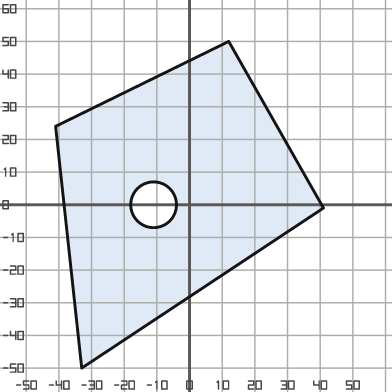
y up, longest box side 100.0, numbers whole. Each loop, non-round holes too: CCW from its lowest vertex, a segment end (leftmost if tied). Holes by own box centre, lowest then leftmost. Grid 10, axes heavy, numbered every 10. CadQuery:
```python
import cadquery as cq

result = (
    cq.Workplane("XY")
    .moveTo(-33.0, -50.0)
    .lineTo(41.0, -1.0)
    .lineTo(12.0, 50.0)
    .lineTo(-41.0, 24.0)
    .close()
    .moveTo(-11.0, 0.0)
    .circle(7.0)
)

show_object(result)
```